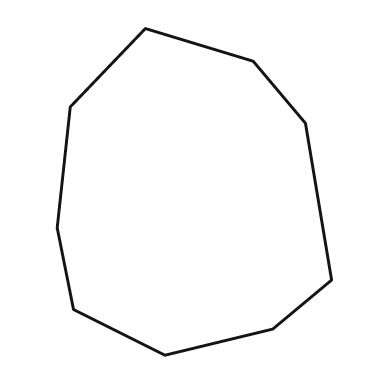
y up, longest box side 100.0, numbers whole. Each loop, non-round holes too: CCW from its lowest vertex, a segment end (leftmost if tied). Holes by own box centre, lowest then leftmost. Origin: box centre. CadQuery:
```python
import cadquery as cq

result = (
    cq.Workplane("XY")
    .moveTo(-9.0, -50.0)
    .lineTo(24.0, -42.0)
    .lineTo(42.0, -27.0)
    .lineTo(34.0, 21.0)
    .lineTo(18.0, 40.0)
    .lineTo(-15.0, 50.0)
    .lineTo(-38.0, 26.0)
    .lineTo(-42.0, -11.0)
    .lineTo(-37.0, -36.0)
    .close()
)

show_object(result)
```